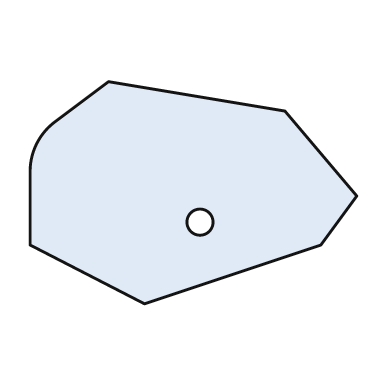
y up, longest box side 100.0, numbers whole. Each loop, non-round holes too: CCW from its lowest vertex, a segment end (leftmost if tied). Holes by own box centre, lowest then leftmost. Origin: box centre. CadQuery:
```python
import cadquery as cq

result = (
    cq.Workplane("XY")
    .moveTo(-15.0, -34.0)
    .lineTo(39.0, -16.0)
    .lineTo(50.0, -1.0)
    .lineTo(28.0, 25.0)
    .lineTo(-26.0, 34.0)
    .lineTo(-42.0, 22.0)
    .threePointArc((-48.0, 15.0), (-50.0, 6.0))
    .lineTo(-50.0, -16.0)
    .close()
    .moveTo(2.0, -9.0)
    .circle(4.0)
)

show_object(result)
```